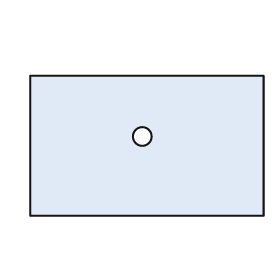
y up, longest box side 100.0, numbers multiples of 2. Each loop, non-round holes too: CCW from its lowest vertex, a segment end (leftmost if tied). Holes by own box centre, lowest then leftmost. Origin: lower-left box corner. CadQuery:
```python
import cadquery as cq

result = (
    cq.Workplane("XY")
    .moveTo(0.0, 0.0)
    .lineTo(100.0, 0.0)
    .lineTo(100.0, 60.0)
    .lineTo(0.0, 60.0)
    .close()
    .moveTo(48.0, 34.0)
    .circle(4.0)
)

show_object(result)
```